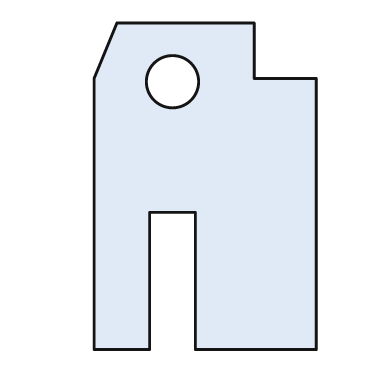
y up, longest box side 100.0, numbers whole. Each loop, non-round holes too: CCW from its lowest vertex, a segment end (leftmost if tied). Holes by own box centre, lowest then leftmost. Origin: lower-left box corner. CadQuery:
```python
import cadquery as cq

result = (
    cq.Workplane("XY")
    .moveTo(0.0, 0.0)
    .lineTo(17.0, 0.0)
    .lineTo(17.0, 42.0)
    .lineTo(31.0, 42.0)
    .lineTo(31.0, 0.0)
    .lineTo(68.0, 0.0)
    .lineTo(68.0, 83.0)
    .lineTo(49.0, 83.0)
    .lineTo(49.0, 100.0)
    .lineTo(7.0, 100.0)
    .lineTo(0.0, 83.0)
    .close()
    .moveTo(24.0, 82.0)
    .circle(8.0)
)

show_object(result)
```